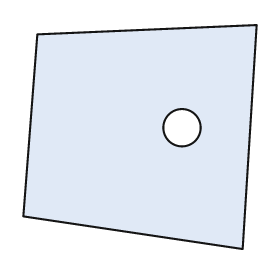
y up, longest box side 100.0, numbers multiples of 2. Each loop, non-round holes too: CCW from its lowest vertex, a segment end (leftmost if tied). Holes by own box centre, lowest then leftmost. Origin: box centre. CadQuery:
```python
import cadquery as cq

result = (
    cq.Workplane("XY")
    .moveTo(44.0, -48.0)
    .lineTo(50.0, 48.0)
    .lineTo(-44.0, 44.0)
    .lineTo(-50.0, -34.0)
    .close()
    .moveTo(18.0, 4.0)
    .circle(8.0)
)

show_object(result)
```